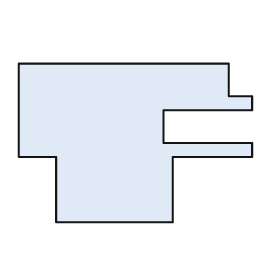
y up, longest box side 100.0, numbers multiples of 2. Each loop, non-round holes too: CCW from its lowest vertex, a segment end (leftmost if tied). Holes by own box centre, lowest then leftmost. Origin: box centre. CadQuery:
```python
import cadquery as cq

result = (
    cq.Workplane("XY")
    .moveTo(-34.0, -34.0)
    .lineTo(16.0, -34.0)
    .lineTo(16.0, -6.0)
    .lineTo(50.0, -6.0)
    .lineTo(50.0, 0.0)
    .lineTo(12.0, 0.0)
    .lineTo(12.0, 14.0)
    .lineTo(50.0, 14.0)
    .lineTo(50.0, 20.0)
    .lineTo(40.0, 20.0)
    .lineTo(40.0, 34.0)
    .lineTo(-50.0, 34.0)
    .lineTo(-50.0, -6.0)
    .lineTo(-34.0, -6.0)
    .close()
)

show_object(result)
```